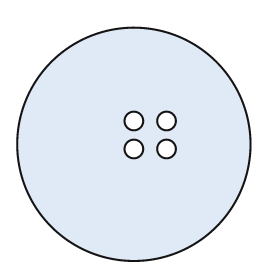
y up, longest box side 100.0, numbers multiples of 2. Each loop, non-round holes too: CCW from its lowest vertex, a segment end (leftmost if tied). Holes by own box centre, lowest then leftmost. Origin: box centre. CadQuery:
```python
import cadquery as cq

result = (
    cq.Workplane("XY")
    .moveTo(0.0, 0.0)
    .circle(50.0)
    .moveTo(0.0, -2.0)
    .circle(4.0)
    .moveTo(14.0, -2.0)
    .circle(4.0)
    .moveTo(0.0, 10.0)
    .circle(4.0)
    .moveTo(14.0, 10.0)
    .circle(4.0)
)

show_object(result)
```